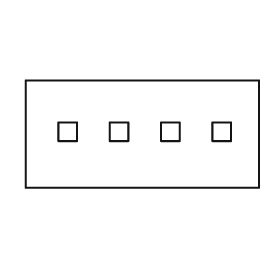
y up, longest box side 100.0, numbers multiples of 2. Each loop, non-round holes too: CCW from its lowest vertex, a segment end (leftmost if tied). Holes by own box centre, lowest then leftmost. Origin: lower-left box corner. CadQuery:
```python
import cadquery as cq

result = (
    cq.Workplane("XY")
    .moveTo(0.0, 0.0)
    .lineTo(100.0, 0.0)
    .lineTo(100.0, 46.0)
    .lineTo(0.0, 46.0)
    .close()
    .moveTo(14.0, 20.0)
    .lineTo(22.0, 20.0)
    .lineTo(22.0, 28.0)
    .lineTo(14.0, 28.0)
    .close()
    .moveTo(36.0, 20.0)
    .lineTo(44.0, 20.0)
    .lineTo(44.0, 28.0)
    .lineTo(36.0, 28.0)
    .close()
    .moveTo(58.0, 20.0)
    .lineTo(66.0, 20.0)
    .lineTo(66.0, 28.0)
    .lineTo(58.0, 28.0)
    .close()
    .moveTo(80.0, 20.0)
    .lineTo(88.0, 20.0)
    .lineTo(88.0, 28.0)
    .lineTo(80.0, 28.0)
    .close()
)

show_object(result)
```